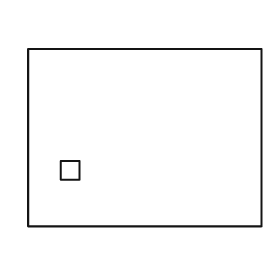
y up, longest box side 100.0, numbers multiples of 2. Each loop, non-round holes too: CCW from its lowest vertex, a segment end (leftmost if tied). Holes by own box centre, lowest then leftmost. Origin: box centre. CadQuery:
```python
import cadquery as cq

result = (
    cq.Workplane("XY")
    .moveTo(-50.0, -38.0)
    .lineTo(50.0, -38.0)
    .lineTo(50.0, 38.0)
    .lineTo(-50.0, 38.0)
    .close()
    .moveTo(-36.0, -18.0)
    .lineTo(-28.0, -18.0)
    .lineTo(-28.0, -10.0)
    .lineTo(-36.0, -10.0)
    .close()
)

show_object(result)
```